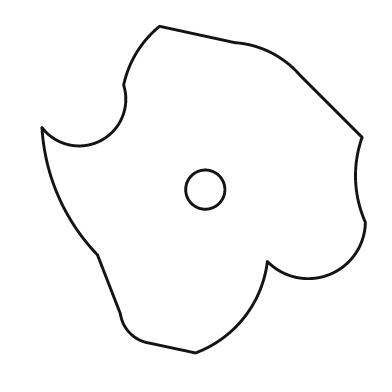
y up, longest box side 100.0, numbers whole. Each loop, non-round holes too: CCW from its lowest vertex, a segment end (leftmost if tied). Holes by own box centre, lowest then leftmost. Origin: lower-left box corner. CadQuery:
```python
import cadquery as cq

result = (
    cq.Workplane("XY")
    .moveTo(47.0, 0.0)
    .threePointArc((62.0, 11.0), (69.0, 28.0))
    .threePointArc((88.0, 24.0), (99.0, 40.0))
    .threePointArc((96.0, 53.0), (98.0, 66.0))
    .lineTo(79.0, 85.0)
    .threePointArc((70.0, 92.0), (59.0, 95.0))
    .lineTo(36.0, 100.0)
    .threePointArc((29.0, 92.0), (25.0, 82.0))
    .threePointArc((18.0, 65.0), (0.0, 69.0))
    .threePointArc((5.0, 48.0), (17.0, 30.0))
    .lineTo(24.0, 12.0)
    .threePointArc((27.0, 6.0), (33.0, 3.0))
    .close()
    .moveTo(50.0, 50.0)
    .circle(6.0)
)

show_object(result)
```